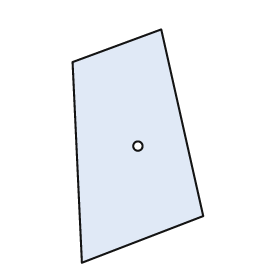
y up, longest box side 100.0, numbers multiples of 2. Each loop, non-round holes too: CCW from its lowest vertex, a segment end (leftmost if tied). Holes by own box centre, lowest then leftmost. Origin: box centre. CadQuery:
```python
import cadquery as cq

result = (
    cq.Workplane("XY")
    .moveTo(-24.0, -50.0)
    .lineTo(28.0, -30.0)
    .lineTo(10.0, 50.0)
    .lineTo(-28.0, 36.0)
    .close()
    .moveTo(0.0, 0.0)
    .circle(2.0)
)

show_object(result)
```